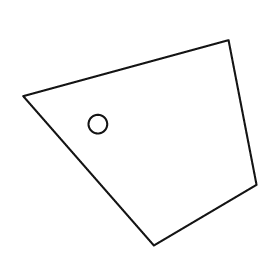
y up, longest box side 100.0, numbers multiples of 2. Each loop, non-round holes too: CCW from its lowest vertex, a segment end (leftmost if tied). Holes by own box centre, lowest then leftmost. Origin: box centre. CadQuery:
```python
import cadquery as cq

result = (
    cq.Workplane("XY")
    .moveTo(6.0, -44.0)
    .lineTo(50.0, -18.0)
    .lineTo(38.0, 44.0)
    .lineTo(-50.0, 20.0)
    .close()
    .moveTo(-18.0, 8.0)
    .circle(4.0)
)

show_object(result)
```